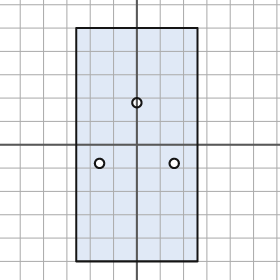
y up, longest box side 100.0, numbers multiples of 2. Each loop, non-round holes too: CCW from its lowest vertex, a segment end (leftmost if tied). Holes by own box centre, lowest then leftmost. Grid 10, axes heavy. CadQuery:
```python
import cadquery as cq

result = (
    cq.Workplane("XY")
    .moveTo(-26.0, -50.0)
    .lineTo(26.0, -50.0)
    .lineTo(26.0, 50.0)
    .lineTo(-26.0, 50.0)
    .close()
    .moveTo(-16.0, -8.0)
    .circle(2.0)
    .moveTo(16.0, -8.0)
    .circle(2.0)
    .moveTo(0.0, 18.0)
    .circle(2.0)
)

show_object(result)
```